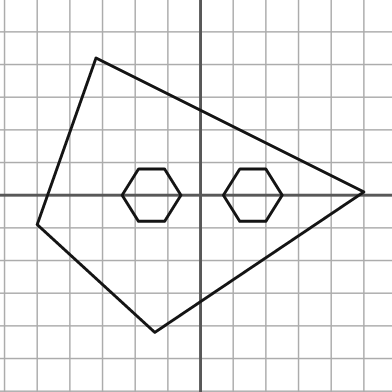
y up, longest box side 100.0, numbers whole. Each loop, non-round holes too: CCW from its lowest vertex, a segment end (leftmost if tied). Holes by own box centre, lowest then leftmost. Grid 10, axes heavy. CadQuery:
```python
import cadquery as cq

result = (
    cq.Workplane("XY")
    .moveTo(-14.0, -42.0)
    .lineTo(50.0, 1.0)
    .lineTo(-32.0, 42.0)
    .lineTo(-50.0, -9.0)
    .close()
    .moveTo(-19.0, -8.0)
    .lineTo(-11.0, -8.0)
    .lineTo(-6.0, 0.0)
    .lineTo(-11.0, 8.0)
    .lineTo(-19.0, 8.0)
    .lineTo(-24.0, 0.0)
    .close()
    .moveTo(12.0, -8.0)
    .lineTo(20.0, -8.0)
    .lineTo(25.0, 0.0)
    .lineTo(20.0, 8.0)
    .lineTo(12.0, 8.0)
    .lineTo(7.0, 0.0)
    .close()
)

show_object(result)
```